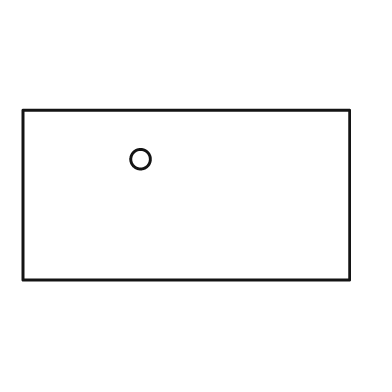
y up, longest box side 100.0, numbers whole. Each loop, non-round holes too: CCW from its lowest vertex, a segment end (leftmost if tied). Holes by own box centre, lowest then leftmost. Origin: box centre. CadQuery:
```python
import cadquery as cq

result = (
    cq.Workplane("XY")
    .moveTo(-50.0, -26.0)
    .lineTo(50.0, -26.0)
    .lineTo(50.0, 26.0)
    .lineTo(-50.0, 26.0)
    .close()
    .moveTo(-14.0, 11.0)
    .circle(3.0)
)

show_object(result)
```